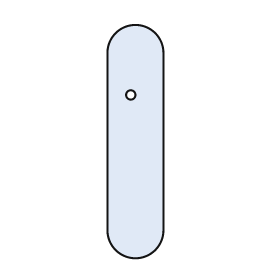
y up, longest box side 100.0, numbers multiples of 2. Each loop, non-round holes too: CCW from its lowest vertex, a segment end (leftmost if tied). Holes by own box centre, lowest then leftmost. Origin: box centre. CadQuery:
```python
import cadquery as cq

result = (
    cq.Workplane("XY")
    .moveTo(-12.0, -38.0)
    .threePointArc((0.0, -50.0), (12.0, -38.0))
    .lineTo(12.0, 38.0)
    .threePointArc((0.0, 50.0), (-12.0, 38.0))
    .close()
    .moveTo(-2.0, 20.0)
    .circle(2.0)
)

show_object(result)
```